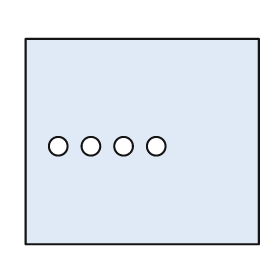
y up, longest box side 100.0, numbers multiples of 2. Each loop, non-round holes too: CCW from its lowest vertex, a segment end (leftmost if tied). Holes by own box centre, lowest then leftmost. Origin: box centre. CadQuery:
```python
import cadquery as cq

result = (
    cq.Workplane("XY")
    .moveTo(-50.0, -44.0)
    .lineTo(50.0, -44.0)
    .lineTo(50.0, 44.0)
    .lineTo(-50.0, 44.0)
    .close()
    .moveTo(-36.0, -2.0)
    .circle(4.0)
    .moveTo(-22.0, -2.0)
    .circle(4.0)
    .moveTo(-8.0, -2.0)
    .circle(4.0)
    .moveTo(6.0, -2.0)
    .circle(4.0)
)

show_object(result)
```